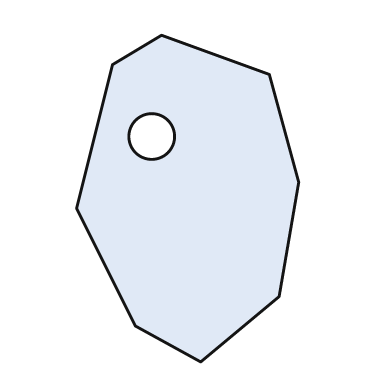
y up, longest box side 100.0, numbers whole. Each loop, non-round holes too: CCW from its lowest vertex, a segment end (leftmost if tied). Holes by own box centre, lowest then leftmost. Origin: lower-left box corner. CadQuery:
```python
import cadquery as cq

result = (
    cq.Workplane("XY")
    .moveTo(38.0, 0.0)
    .lineTo(62.0, 20.0)
    .lineTo(68.0, 55.0)
    .lineTo(59.0, 88.0)
    .lineTo(26.0, 100.0)
    .lineTo(11.0, 91.0)
    .lineTo(0.0, 47.0)
    .lineTo(18.0, 11.0)
    .close()
    .moveTo(23.0, 69.0)
    .circle(7.0)
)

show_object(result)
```